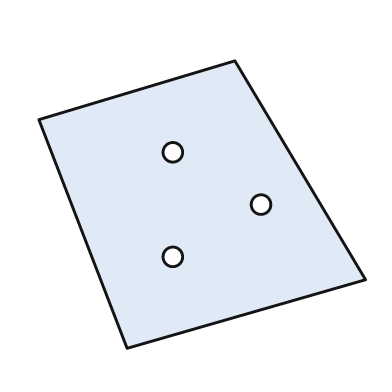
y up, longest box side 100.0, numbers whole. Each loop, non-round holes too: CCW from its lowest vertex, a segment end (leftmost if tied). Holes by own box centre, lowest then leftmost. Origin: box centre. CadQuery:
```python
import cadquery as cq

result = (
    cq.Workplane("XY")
    .moveTo(-23.0, -44.0)
    .lineTo(50.0, -23.0)
    .lineTo(10.0, 44.0)
    .lineTo(-50.0, 26.0)
    .close()
    .moveTo(-9.0, -16.0)
    .circle(3.0)
    .moveTo(18.0, 0.0)
    .circle(3.0)
    .moveTo(-9.0, 16.0)
    .circle(3.0)
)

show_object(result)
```